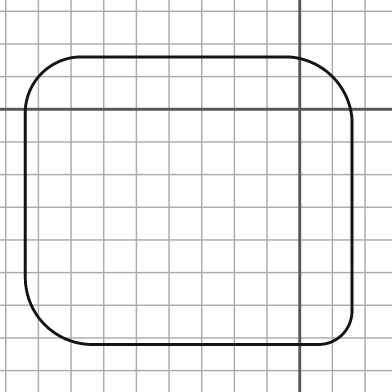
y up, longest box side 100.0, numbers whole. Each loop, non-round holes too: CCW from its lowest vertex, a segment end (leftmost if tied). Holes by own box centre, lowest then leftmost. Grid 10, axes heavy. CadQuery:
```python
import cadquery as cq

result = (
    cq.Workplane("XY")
    .moveTo(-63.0, -72.0)
    .lineTo(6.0, -72.0)
    .threePointArc((13.0, -69.0), (16.0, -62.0))
    .lineTo(16.0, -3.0)
    .threePointArc((10.0, 10.0), (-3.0, 16.0))
    .lineTo(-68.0, 16.0)
    .threePointArc((-79.0, 11.0), (-84.0, 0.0))
    .lineTo(-84.0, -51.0)
    .threePointArc((-78.0, -66.0), (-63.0, -72.0))
    .close()
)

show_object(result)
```